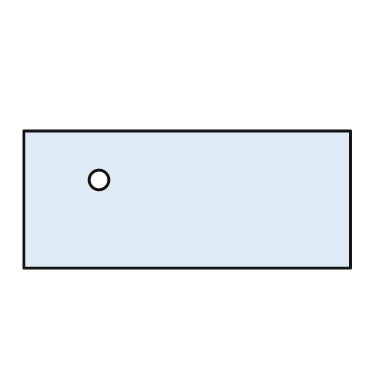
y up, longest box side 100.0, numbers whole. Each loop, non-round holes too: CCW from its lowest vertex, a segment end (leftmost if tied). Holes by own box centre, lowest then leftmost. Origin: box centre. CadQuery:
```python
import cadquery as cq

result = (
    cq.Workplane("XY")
    .moveTo(-50.0, -21.0)
    .lineTo(50.0, -21.0)
    .lineTo(50.0, 21.0)
    .lineTo(-50.0, 21.0)
    .close()
    .moveTo(-27.0, 6.0)
    .circle(3.0)
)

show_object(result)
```